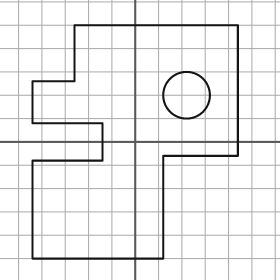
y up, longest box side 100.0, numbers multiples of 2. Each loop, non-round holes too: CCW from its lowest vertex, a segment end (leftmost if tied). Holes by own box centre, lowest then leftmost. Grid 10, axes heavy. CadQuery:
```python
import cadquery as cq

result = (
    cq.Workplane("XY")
    .moveTo(-44.0, -50.0)
    .lineTo(12.0, -50.0)
    .lineTo(12.0, -6.0)
    .lineTo(44.0, -6.0)
    .lineTo(44.0, 50.0)
    .lineTo(-26.0, 50.0)
    .lineTo(-26.0, 26.0)
    .lineTo(-44.0, 26.0)
    .lineTo(-44.0, 8.0)
    .lineTo(-14.0, 8.0)
    .lineTo(-14.0, -8.0)
    .lineTo(-44.0, -8.0)
    .close()
    .moveTo(22.0, 20.0)
    .circle(10.0)
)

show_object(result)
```